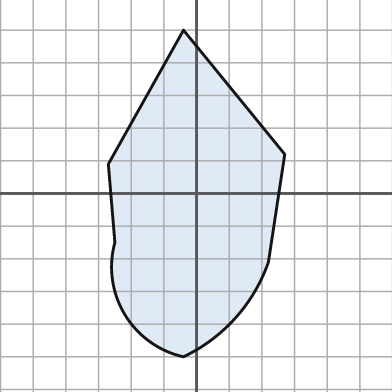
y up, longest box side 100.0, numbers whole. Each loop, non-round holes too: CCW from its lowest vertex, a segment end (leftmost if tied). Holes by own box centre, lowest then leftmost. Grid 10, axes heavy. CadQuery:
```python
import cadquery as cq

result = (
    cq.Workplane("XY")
    .moveTo(-4.0, -50.0)
    .threePointArc((12.0, -38.0), (22.0, -21.0))
    .lineTo(27.0, 12.0)
    .lineTo(-4.0, 50.0)
    .lineTo(-27.0, 9.0)
    .lineTo(-25.0, -15.0)
    .threePointArc((-22.0, -37.0), (-4.0, -50.0))
    .close()
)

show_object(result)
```